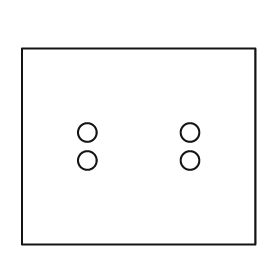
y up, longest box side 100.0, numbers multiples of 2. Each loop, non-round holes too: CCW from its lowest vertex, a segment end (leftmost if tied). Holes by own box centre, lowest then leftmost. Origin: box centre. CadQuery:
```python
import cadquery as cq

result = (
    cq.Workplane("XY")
    .moveTo(-50.0, -42.0)
    .lineTo(50.0, -42.0)
    .lineTo(50.0, 42.0)
    .lineTo(-50.0, 42.0)
    .close()
    .moveTo(-22.0, -6.0)
    .circle(4.0)
    .moveTo(22.0, -6.0)
    .circle(4.0)
    .moveTo(-22.0, 6.0)
    .circle(4.0)
    .moveTo(22.0, 6.0)
    .circle(4.0)
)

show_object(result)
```